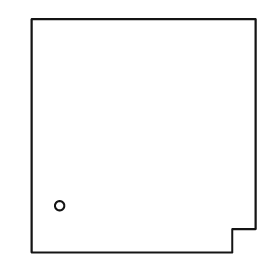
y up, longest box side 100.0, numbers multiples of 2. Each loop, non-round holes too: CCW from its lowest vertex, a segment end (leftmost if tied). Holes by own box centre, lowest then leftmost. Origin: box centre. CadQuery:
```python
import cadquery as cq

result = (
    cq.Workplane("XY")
    .moveTo(-48.0, -50.0)
    .lineTo(38.0, -50.0)
    .lineTo(38.0, -40.0)
    .lineTo(48.0, -40.0)
    .lineTo(48.0, 50.0)
    .lineTo(-48.0, 50.0)
    .close()
    .moveTo(-36.0, -30.0)
    .circle(2.0)
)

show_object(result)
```